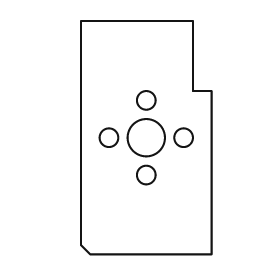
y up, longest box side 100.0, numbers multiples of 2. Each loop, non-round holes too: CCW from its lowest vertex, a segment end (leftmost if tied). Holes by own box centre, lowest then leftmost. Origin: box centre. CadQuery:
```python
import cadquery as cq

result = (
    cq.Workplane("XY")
    .moveTo(-24.0, -50.0)
    .lineTo(28.0, -50.0)
    .lineTo(28.0, 20.0)
    .lineTo(20.0, 20.0)
    .lineTo(20.0, 50.0)
    .lineTo(-28.0, 50.0)
    .lineTo(-28.0, -46.0)
    .close()
    .moveTo(0.0, -16.0)
    .circle(4.0)
    .moveTo(-16.0, 0.0)
    .circle(4.0)
    .moveTo(0.0, 0.0)
    .circle(8.0)
    .moveTo(16.0, 0.0)
    .circle(4.0)
    .moveTo(0.0, 16.0)
    .circle(4.0)
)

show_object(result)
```